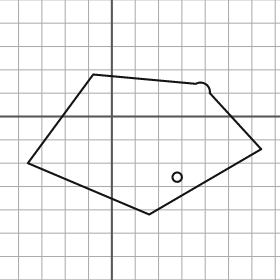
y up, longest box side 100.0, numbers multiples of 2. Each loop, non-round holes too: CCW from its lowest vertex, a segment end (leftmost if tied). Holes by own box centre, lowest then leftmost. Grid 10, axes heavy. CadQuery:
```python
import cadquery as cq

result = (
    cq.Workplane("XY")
    .moveTo(16.0, -42.0)
    .lineTo(64.0, -14.0)
    .lineTo(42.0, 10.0)
    .threePointArc((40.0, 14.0), (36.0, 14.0))
    .lineTo(-8.0, 18.0)
    .lineTo(-36.0, -20.0)
    .close()
    .moveTo(28.0, -26.0)
    .circle(2.0)
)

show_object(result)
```